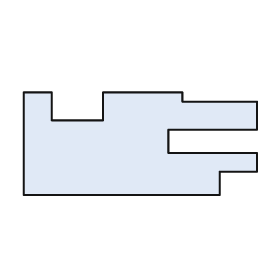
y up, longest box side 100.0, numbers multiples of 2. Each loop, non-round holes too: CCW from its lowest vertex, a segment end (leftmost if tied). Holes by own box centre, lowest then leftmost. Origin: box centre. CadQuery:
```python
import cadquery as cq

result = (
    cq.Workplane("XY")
    .moveTo(-50.0, -22.0)
    .lineTo(34.0, -22.0)
    .lineTo(34.0, -12.0)
    .lineTo(50.0, -12.0)
    .lineTo(50.0, -4.0)
    .lineTo(12.0, -4.0)
    .lineTo(12.0, 6.0)
    .lineTo(50.0, 6.0)
    .lineTo(50.0, 18.0)
    .lineTo(18.0, 18.0)
    .lineTo(18.0, 22.0)
    .lineTo(-16.0, 22.0)
    .lineTo(-16.0, 10.0)
    .lineTo(-38.0, 10.0)
    .lineTo(-38.0, 22.0)
    .lineTo(-50.0, 22.0)
    .close()
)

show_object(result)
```